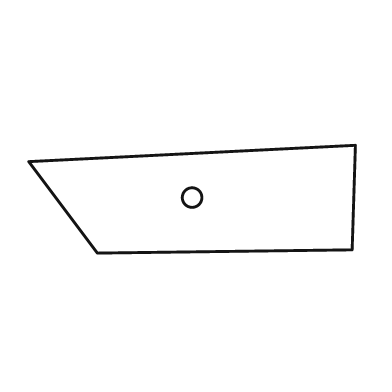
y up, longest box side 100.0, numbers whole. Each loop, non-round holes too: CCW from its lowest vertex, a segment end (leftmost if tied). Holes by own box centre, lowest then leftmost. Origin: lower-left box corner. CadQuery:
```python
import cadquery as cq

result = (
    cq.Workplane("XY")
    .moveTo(21.0, 0.0)
    .lineTo(99.0, 1.0)
    .lineTo(100.0, 33.0)
    .lineTo(0.0, 28.0)
    .close()
    .moveTo(50.0, 17.0)
    .circle(3.0)
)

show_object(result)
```